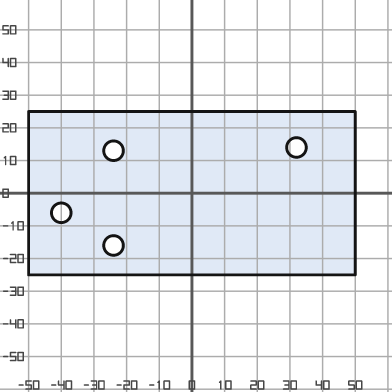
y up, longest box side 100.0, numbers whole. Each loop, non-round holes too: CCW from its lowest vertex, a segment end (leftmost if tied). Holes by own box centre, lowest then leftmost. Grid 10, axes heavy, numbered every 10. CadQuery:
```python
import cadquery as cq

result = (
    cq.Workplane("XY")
    .moveTo(-50.0, -25.0)
    .lineTo(50.0, -25.0)
    .lineTo(50.0, 25.0)
    .lineTo(-50.0, 25.0)
    .close()
    .moveTo(-24.0, -16.0)
    .circle(3.0)
    .moveTo(-40.0, -6.0)
    .circle(3.0)
    .moveTo(-24.0, 13.0)
    .circle(3.0)
    .moveTo(32.0, 14.0)
    .circle(3.0)
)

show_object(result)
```